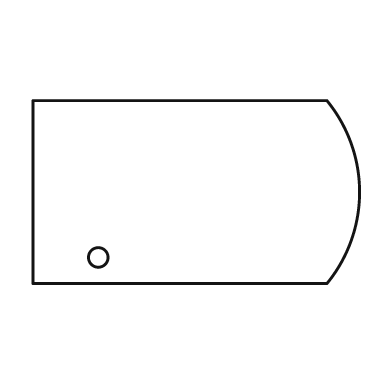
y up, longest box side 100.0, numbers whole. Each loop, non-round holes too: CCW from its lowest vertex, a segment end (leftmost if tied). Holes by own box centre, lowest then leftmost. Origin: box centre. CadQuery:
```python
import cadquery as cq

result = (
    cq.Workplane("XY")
    .moveTo(-50.0, -28.0)
    .lineTo(40.0, -28.0)
    .threePointArc((50.0, 0.0), (40.0, 28.0))
    .lineTo(-50.0, 28.0)
    .close()
    .moveTo(-30.0, -20.0)
    .circle(3.0)
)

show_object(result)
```